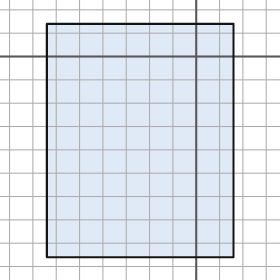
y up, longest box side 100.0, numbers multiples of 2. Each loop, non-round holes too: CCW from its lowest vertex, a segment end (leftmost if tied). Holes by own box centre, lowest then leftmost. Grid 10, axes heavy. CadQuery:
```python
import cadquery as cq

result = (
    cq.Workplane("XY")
    .moveTo(-64.0, -86.0)
    .lineTo(16.0, -86.0)
    .lineTo(16.0, 14.0)
    .lineTo(-64.0, 14.0)
    .close()
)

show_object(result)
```